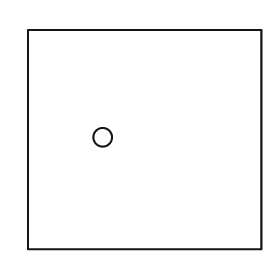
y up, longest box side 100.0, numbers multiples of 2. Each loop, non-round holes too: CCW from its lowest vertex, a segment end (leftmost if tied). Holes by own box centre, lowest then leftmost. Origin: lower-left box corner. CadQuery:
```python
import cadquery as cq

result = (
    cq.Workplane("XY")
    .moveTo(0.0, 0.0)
    .lineTo(100.0, 0.0)
    .lineTo(100.0, 94.0)
    .lineTo(0.0, 94.0)
    .close()
    .moveTo(32.0, 48.0)
    .circle(4.0)
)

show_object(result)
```